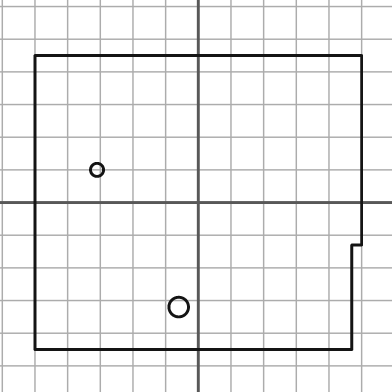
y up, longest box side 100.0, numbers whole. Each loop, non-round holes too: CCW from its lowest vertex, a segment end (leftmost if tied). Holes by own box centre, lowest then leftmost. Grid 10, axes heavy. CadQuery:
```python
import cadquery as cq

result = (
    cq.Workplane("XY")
    .moveTo(-50.0, -45.0)
    .lineTo(47.0, -45.0)
    .lineTo(47.0, -13.0)
    .lineTo(50.0, -13.0)
    .lineTo(50.0, 45.0)
    .lineTo(-50.0, 45.0)
    .close()
    .moveTo(-6.0, -32.0)
    .circle(3.0)
    .moveTo(-31.0, 10.0)
    .circle(2.0)
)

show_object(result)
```